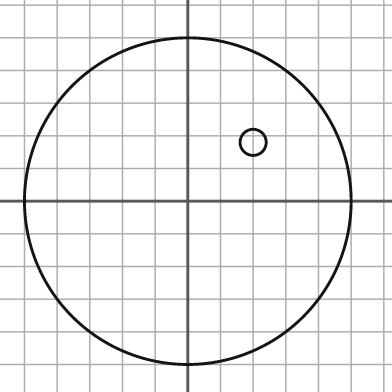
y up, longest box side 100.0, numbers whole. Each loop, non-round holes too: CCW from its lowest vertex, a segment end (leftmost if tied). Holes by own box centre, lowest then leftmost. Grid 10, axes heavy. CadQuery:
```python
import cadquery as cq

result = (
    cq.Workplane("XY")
    .moveTo(0.0, 0.0)
    .circle(50.0)
    .moveTo(20.0, 18.0)
    .circle(4.0)
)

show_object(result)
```